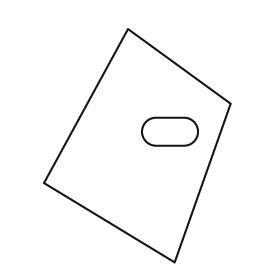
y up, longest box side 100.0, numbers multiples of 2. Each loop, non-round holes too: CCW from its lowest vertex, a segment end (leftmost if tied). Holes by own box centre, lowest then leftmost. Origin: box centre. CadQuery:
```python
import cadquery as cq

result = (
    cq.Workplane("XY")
    .moveTo(16.0, -50.0)
    .lineTo(40.0, 18.0)
    .lineTo(-4.0, 50.0)
    .lineTo(-40.0, -16.0)
    .close()
    .moveTo(8.0, 0.0)
    .lineTo(20.0, 0.0)
    .threePointArc((26.0, 6.0), (20.0, 12.0))
    .lineTo(8.0, 12.0)
    .threePointArc((2.0, 6.0), (8.0, 0.0))
    .close()
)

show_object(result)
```